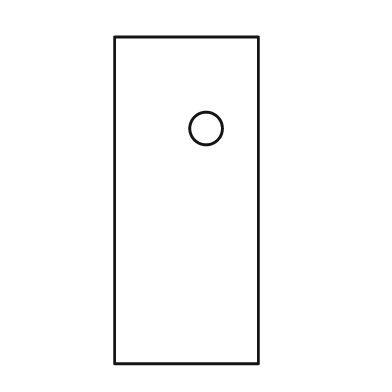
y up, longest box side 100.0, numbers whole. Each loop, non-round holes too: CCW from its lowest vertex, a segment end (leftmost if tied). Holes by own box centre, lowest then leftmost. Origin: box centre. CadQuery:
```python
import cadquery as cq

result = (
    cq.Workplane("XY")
    .moveTo(-22.0, -50.0)
    .lineTo(22.0, -50.0)
    .lineTo(22.0, 50.0)
    .lineTo(-22.0, 50.0)
    .close()
    .moveTo(6.0, 22.0)
    .circle(5.0)
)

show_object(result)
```